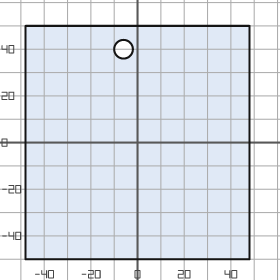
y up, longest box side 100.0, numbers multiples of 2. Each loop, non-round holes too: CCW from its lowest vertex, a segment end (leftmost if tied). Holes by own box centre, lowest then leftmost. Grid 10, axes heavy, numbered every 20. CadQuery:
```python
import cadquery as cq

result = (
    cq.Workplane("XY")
    .moveTo(-48.0, -50.0)
    .lineTo(48.0, -50.0)
    .lineTo(48.0, 50.0)
    .lineTo(-48.0, 50.0)
    .close()
    .moveTo(-6.0, 40.0)
    .circle(4.0)
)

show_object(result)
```